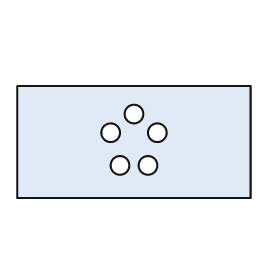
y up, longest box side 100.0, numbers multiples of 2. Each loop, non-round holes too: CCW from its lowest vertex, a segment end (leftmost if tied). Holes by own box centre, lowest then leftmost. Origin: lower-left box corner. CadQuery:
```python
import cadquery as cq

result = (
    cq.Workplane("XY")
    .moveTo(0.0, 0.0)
    .lineTo(100.0, 0.0)
    .lineTo(100.0, 48.0)
    .lineTo(0.0, 48.0)
    .close()
    .moveTo(44.0, 14.0)
    .circle(4.0)
    .moveTo(56.0, 14.0)
    .circle(4.0)
    .moveTo(40.0, 28.0)
    .circle(4.0)
    .moveTo(60.0, 28.0)
    .circle(4.0)
    .moveTo(50.0, 36.0)
    .circle(4.0)
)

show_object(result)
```